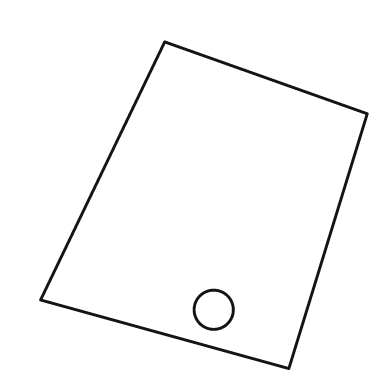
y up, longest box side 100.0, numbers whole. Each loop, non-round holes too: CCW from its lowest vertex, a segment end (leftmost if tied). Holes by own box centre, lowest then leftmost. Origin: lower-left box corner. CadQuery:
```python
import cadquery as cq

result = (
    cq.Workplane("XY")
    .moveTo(76.0, 0.0)
    .lineTo(100.0, 78.0)
    .lineTo(38.0, 100.0)
    .lineTo(0.0, 21.0)
    .close()
    .moveTo(53.0, 18.0)
    .circle(6.0)
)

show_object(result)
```